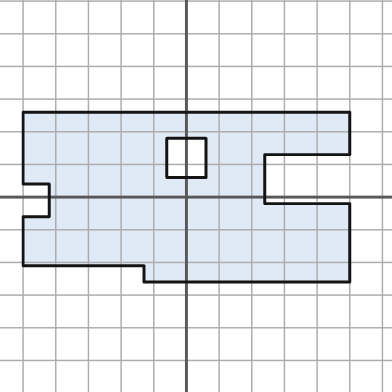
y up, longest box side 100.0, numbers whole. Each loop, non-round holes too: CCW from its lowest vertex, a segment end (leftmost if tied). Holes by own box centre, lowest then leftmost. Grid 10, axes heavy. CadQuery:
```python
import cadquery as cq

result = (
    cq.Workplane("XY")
    .moveTo(-13.0, -26.0)
    .lineTo(50.0, -26.0)
    .lineTo(50.0, -2.0)
    .lineTo(24.0, -2.0)
    .lineTo(24.0, 13.0)
    .lineTo(50.0, 13.0)
    .lineTo(50.0, 26.0)
    .lineTo(-50.0, 26.0)
    .lineTo(-50.0, 4.0)
    .lineTo(-42.0, 4.0)
    .lineTo(-42.0, -6.0)
    .lineTo(-50.0, -6.0)
    .lineTo(-50.0, -21.0)
    .lineTo(-13.0, -21.0)
    .close()
    .moveTo(-6.0, 6.0)
    .lineTo(6.0, 6.0)
    .lineTo(6.0, 18.0)
    .lineTo(-6.0, 18.0)
    .close()
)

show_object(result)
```